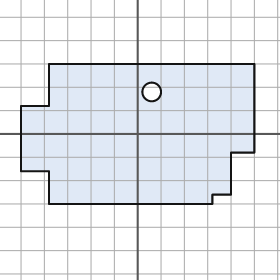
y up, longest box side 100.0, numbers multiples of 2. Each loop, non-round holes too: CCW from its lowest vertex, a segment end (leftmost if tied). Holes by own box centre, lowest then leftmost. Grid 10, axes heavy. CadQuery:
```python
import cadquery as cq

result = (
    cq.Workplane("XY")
    .moveTo(-38.0, -30.0)
    .lineTo(32.0, -30.0)
    .lineTo(32.0, -26.0)
    .lineTo(40.0, -26.0)
    .lineTo(40.0, -8.0)
    .lineTo(50.0, -8.0)
    .lineTo(50.0, 30.0)
    .lineTo(-38.0, 30.0)
    .lineTo(-38.0, 12.0)
    .lineTo(-50.0, 12.0)
    .lineTo(-50.0, -16.0)
    .lineTo(-38.0, -16.0)
    .close()
    .moveTo(6.0, 18.0)
    .circle(4.0)
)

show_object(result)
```